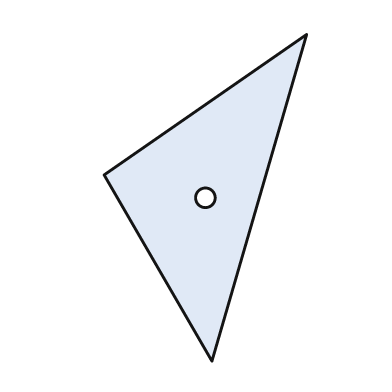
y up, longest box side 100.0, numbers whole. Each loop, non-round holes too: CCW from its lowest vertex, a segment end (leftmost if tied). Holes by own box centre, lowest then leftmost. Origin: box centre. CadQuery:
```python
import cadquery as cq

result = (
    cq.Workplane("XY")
    .moveTo(2.0, -50.0)
    .lineTo(31.0, 50.0)
    .lineTo(-31.0, 7.0)
    .close()
    .moveTo(0.0, 0.0)
    .circle(3.0)
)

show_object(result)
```